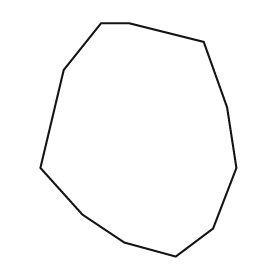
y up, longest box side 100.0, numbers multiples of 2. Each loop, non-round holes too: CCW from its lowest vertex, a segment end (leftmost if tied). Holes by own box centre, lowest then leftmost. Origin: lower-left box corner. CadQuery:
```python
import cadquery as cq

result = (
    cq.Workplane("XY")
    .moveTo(58.0, 0.0)
    .lineTo(74.0, 12.0)
    .lineTo(84.0, 38.0)
    .lineTo(80.0, 64.0)
    .lineTo(70.0, 92.0)
    .lineTo(38.0, 100.0)
    .lineTo(26.0, 100.0)
    .lineTo(10.0, 80.0)
    .lineTo(0.0, 38.0)
    .lineTo(18.0, 18.0)
    .lineTo(36.0, 6.0)
    .close()
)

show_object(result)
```